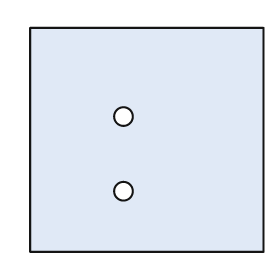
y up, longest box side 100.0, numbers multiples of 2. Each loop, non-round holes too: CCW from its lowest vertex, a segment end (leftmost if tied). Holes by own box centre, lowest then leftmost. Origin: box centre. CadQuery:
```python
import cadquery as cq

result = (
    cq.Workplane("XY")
    .moveTo(-50.0, -48.0)
    .lineTo(50.0, -48.0)
    .lineTo(50.0, 48.0)
    .lineTo(-50.0, 48.0)
    .close()
    .moveTo(-10.0, -22.0)
    .circle(4.0)
    .moveTo(-10.0, 10.0)
    .circle(4.0)
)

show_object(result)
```